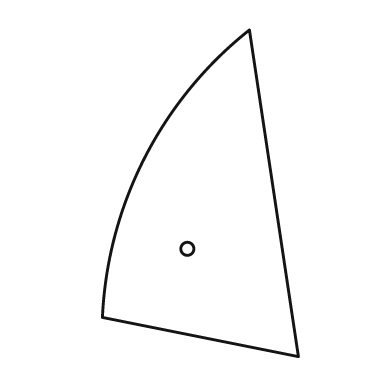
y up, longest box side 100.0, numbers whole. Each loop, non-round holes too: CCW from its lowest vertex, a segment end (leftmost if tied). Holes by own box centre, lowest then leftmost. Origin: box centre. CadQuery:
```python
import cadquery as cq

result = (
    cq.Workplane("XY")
    .moveTo(30.0, -50.0)
    .lineTo(15.0, 50.0)
    .threePointArc((-17.0, 11.0), (-30.0, -38.0))
    .close()
    .moveTo(-4.0, -17.0)
    .circle(2.0)
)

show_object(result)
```